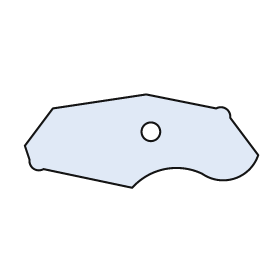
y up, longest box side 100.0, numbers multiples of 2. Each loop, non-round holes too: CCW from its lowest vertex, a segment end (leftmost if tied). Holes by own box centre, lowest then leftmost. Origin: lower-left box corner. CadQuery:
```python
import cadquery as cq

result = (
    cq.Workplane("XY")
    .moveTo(46.0, 0.0)
    .threePointArc((60.0, 8.0), (76.0, 6.0))
    .threePointArc((90.0, 4.0), (100.0, 14.0))
    .lineTo(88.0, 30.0)
    .threePointArc((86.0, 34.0), (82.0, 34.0))
    .lineTo(52.0, 40.0)
    .lineTo(12.0, 34.0)
    .lineTo(0.0, 18.0)
    .lineTo(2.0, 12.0)
    .threePointArc((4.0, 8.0), (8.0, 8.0))
    .close()
    .moveTo(54.0, 24.0)
    .circle(4.0)
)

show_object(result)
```